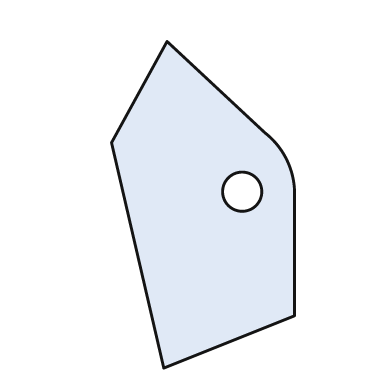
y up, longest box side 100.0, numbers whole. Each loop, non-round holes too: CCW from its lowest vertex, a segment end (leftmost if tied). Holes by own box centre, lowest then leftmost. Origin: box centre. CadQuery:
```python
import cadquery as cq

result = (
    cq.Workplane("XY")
    .moveTo(-12.0, -50.0)
    .lineTo(28.0, -34.0)
    .lineTo(28.0, 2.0)
    .threePointArc((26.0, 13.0), (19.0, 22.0))
    .lineTo(-11.0, 50.0)
    .lineTo(-28.0, 19.0)
    .close()
    .moveTo(12.0, 4.0)
    .circle(6.0)
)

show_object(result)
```